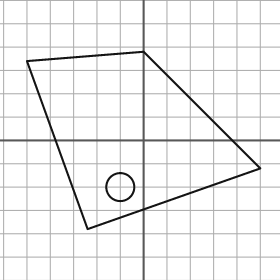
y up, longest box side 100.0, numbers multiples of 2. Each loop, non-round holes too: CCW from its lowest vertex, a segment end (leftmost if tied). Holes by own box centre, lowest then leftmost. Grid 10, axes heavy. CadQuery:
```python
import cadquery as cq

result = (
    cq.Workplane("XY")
    .moveTo(-24.0, -38.0)
    .lineTo(50.0, -12.0)
    .lineTo(0.0, 38.0)
    .lineTo(-50.0, 34.0)
    .close()
    .moveTo(-10.0, -20.0)
    .circle(6.0)
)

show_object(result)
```